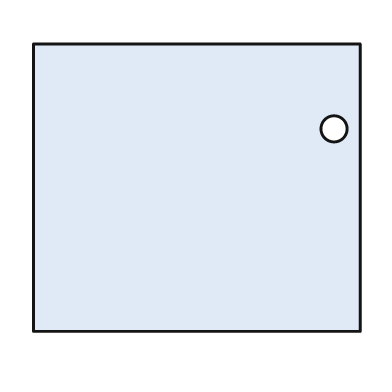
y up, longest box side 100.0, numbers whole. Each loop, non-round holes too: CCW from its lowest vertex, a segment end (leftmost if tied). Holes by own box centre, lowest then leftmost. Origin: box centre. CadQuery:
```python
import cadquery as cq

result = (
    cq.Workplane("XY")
    .moveTo(-50.0, -44.0)
    .lineTo(50.0, -44.0)
    .lineTo(50.0, 44.0)
    .lineTo(-50.0, 44.0)
    .close()
    .moveTo(42.0, 18.0)
    .circle(4.0)
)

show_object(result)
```